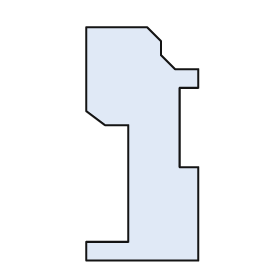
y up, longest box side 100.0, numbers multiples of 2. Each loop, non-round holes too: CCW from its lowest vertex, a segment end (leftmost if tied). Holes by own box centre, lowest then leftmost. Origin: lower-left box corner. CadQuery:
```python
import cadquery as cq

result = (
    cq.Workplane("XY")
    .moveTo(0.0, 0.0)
    .lineTo(48.0, 0.0)
    .lineTo(48.0, 40.0)
    .lineTo(40.0, 40.0)
    .lineTo(40.0, 74.0)
    .lineTo(48.0, 74.0)
    .lineTo(48.0, 82.0)
    .lineTo(38.0, 82.0)
    .lineTo(32.0, 88.0)
    .lineTo(32.0, 94.0)
    .lineTo(26.0, 100.0)
    .lineTo(0.0, 100.0)
    .lineTo(0.0, 64.0)
    .lineTo(8.0, 58.0)
    .lineTo(18.0, 58.0)
    .lineTo(18.0, 8.0)
    .lineTo(0.0, 8.0)
    .close()
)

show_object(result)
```